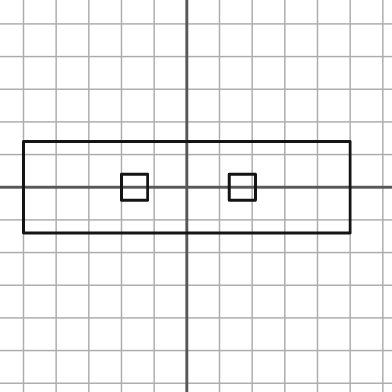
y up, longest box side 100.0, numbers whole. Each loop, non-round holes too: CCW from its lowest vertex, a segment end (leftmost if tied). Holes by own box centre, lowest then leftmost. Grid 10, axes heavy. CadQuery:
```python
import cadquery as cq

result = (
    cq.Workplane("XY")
    .moveTo(-50.0, -14.0)
    .lineTo(50.0, -14.0)
    .lineTo(50.0, 14.0)
    .lineTo(-50.0, 14.0)
    .close()
    .moveTo(-20.0, -4.0)
    .lineTo(-12.0, -4.0)
    .lineTo(-12.0, 4.0)
    .lineTo(-20.0, 4.0)
    .close()
    .moveTo(13.0, -4.0)
    .lineTo(21.0, -4.0)
    .lineTo(21.0, 4.0)
    .lineTo(13.0, 4.0)
    .close()
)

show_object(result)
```